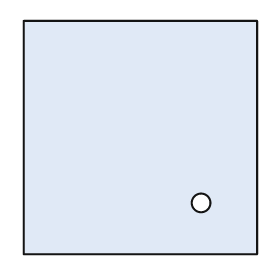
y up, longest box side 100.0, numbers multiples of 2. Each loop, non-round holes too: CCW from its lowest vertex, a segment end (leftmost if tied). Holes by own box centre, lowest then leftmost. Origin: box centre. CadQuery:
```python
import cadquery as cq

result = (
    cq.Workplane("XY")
    .moveTo(-50.0, -50.0)
    .lineTo(50.0, -50.0)
    .lineTo(50.0, 50.0)
    .lineTo(-50.0, 50.0)
    .close()
    .moveTo(26.0, -28.0)
    .circle(4.0)
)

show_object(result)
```